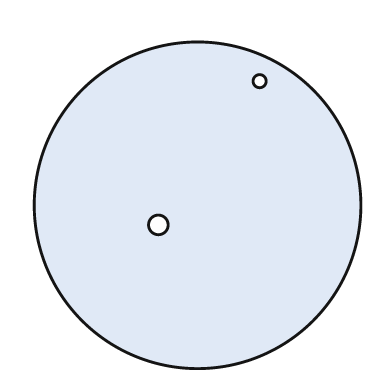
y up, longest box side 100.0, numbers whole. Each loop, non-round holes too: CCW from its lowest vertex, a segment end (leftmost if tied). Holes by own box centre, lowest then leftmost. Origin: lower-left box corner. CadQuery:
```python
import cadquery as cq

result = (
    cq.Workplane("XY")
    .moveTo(50.0, 50.0)
    .circle(50.0)
    .moveTo(38.0, 44.0)
    .circle(3.0)
    .moveTo(69.0, 88.0)
    .circle(2.0)
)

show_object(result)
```